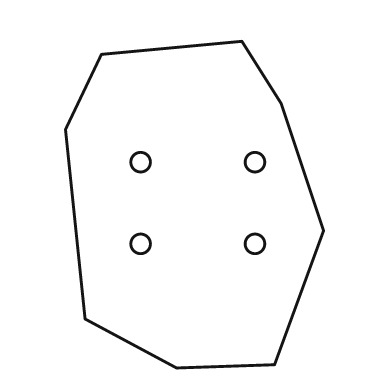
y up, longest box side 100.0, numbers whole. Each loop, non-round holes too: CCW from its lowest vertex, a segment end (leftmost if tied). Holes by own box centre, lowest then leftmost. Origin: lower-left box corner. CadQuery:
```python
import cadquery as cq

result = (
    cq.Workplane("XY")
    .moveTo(34.0, 0.0)
    .lineTo(64.0, 1.0)
    .lineTo(79.0, 42.0)
    .lineTo(66.0, 81.0)
    .lineTo(54.0, 100.0)
    .lineTo(11.0, 96.0)
    .lineTo(0.0, 73.0)
    .lineTo(6.0, 15.0)
    .close()
    .moveTo(23.0, 38.0)
    .circle(3.0)
    .moveTo(58.0, 38.0)
    .circle(3.0)
    .moveTo(23.0, 63.0)
    .circle(3.0)
    .moveTo(58.0, 63.0)
    .circle(3.0)
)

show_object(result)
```